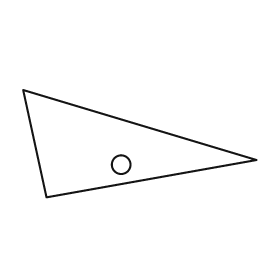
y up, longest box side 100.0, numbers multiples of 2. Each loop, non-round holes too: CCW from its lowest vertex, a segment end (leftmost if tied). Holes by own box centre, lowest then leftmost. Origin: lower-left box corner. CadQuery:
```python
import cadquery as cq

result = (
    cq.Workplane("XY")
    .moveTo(10.0, 0.0)
    .lineTo(100.0, 16.0)
    .lineTo(0.0, 46.0)
    .close()
    .moveTo(42.0, 14.0)
    .circle(4.0)
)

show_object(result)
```